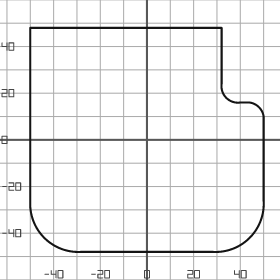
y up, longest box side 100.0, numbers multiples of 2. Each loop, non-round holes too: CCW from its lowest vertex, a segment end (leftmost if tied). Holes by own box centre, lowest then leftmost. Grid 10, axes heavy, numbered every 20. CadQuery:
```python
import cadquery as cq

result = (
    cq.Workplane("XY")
    .moveTo(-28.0, -48.0)
    .lineTo(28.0, -48.0)
    .threePointArc((44.0, -42.0), (50.0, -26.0))
    .lineTo(50.0, 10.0)
    .threePointArc((48.0, 14.0), (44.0, 16.0))
    .lineTo(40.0, 16.0)
    .threePointArc((34.0, 18.0), (32.0, 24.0))
    .lineTo(32.0, 48.0)
    .lineTo(-50.0, 48.0)
    .lineTo(-50.0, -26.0)
    .threePointArc((-44.0, -42.0), (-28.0, -48.0))
    .close()
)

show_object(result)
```